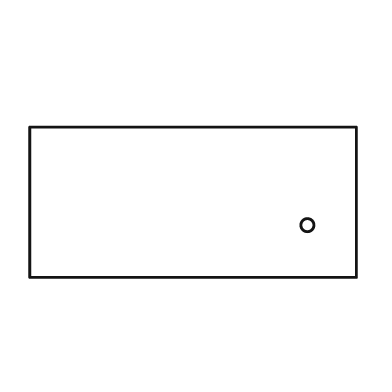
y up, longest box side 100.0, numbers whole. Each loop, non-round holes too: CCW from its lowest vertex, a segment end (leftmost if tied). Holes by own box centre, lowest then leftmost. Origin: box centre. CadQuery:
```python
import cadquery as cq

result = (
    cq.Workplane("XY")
    .moveTo(-50.0, -23.0)
    .lineTo(50.0, -23.0)
    .lineTo(50.0, 23.0)
    .lineTo(-50.0, 23.0)
    .close()
    .moveTo(35.0, -7.0)
    .circle(2.0)
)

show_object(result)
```